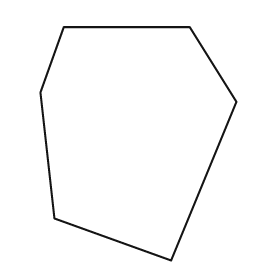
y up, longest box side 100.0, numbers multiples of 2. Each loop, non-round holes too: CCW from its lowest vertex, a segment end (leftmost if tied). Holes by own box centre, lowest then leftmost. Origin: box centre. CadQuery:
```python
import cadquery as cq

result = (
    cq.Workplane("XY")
    .moveTo(14.0, -50.0)
    .lineTo(42.0, 18.0)
    .lineTo(22.0, 50.0)
    .lineTo(-32.0, 50.0)
    .lineTo(-42.0, 22.0)
    .lineTo(-36.0, -32.0)
    .close()
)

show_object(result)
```